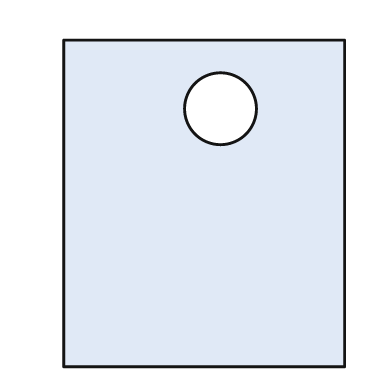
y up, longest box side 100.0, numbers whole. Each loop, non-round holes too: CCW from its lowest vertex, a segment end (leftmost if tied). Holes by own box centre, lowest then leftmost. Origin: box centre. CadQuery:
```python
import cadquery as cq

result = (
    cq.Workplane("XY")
    .moveTo(-43.0, -50.0)
    .lineTo(43.0, -50.0)
    .lineTo(43.0, 50.0)
    .lineTo(-43.0, 50.0)
    .close()
    .moveTo(5.0, 29.0)
    .circle(11.0)
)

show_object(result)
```